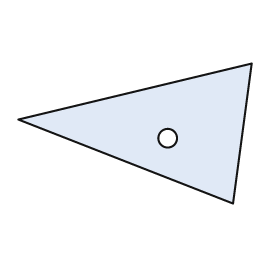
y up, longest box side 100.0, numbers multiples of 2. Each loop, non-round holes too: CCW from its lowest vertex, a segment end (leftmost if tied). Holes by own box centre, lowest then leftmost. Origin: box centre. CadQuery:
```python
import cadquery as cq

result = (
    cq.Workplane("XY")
    .moveTo(42.0, -30.0)
    .lineTo(50.0, 30.0)
    .lineTo(-50.0, 6.0)
    .close()
    .moveTo(14.0, -2.0)
    .circle(4.0)
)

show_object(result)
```